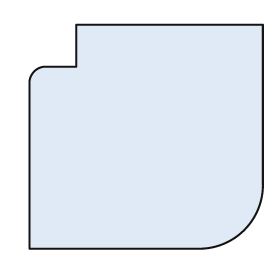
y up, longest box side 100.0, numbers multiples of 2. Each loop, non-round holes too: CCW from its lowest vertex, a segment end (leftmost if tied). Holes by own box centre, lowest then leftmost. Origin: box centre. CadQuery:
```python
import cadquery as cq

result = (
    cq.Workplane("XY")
    .moveTo(-50.0, -48.0)
    .lineTo(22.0, -48.0)
    .threePointArc((42.0, -40.0), (50.0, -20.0))
    .lineTo(50.0, 48.0)
    .lineTo(-30.0, 48.0)
    .lineTo(-30.0, 30.0)
    .lineTo(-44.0, 30.0)
    .threePointArc((-48.0, 28.0), (-50.0, 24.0))
    .close()
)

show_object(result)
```